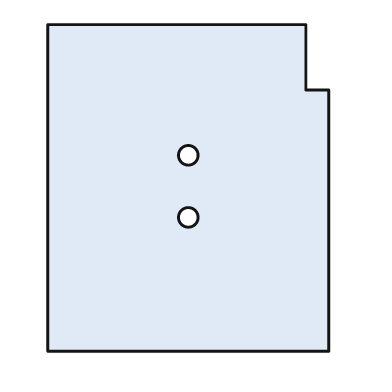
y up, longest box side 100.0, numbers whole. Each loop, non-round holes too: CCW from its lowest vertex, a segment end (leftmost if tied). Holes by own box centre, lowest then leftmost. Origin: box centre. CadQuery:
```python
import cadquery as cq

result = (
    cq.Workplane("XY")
    .moveTo(-43.0, -50.0)
    .lineTo(43.0, -50.0)
    .lineTo(43.0, 30.0)
    .lineTo(36.0, 30.0)
    .lineTo(36.0, 50.0)
    .lineTo(-43.0, 50.0)
    .close()
    .moveTo(0.0, -9.0)
    .circle(3.0)
    .moveTo(0.0, 10.0)
    .circle(3.0)
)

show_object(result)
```